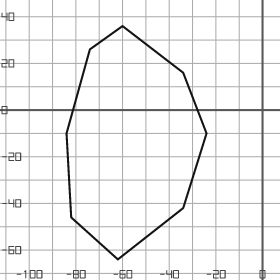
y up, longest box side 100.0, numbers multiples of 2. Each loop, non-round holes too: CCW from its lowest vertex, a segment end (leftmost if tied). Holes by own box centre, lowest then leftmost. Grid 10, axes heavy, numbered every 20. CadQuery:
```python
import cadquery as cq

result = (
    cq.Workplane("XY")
    .moveTo(-62.0, -64.0)
    .lineTo(-34.0, -42.0)
    .lineTo(-24.0, -10.0)
    .lineTo(-34.0, 16.0)
    .lineTo(-60.0, 36.0)
    .lineTo(-74.0, 26.0)
    .lineTo(-84.0, -10.0)
    .lineTo(-82.0, -46.0)
    .close()
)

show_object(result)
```